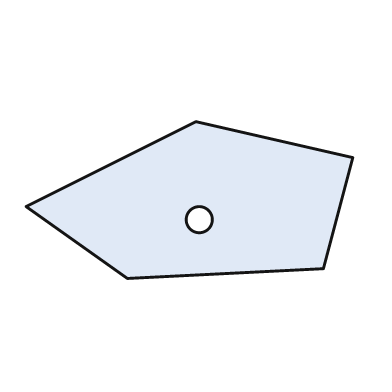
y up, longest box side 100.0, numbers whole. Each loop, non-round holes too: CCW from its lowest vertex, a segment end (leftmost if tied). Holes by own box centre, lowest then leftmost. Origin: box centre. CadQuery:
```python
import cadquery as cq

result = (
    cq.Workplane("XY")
    .moveTo(-19.0, -24.0)
    .lineTo(41.0, -21.0)
    .lineTo(50.0, 13.0)
    .lineTo(2.0, 24.0)
    .lineTo(-50.0, -2.0)
    .close()
    .moveTo(3.0, -6.0)
    .circle(4.0)
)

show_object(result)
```